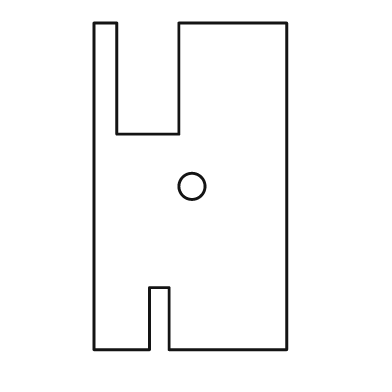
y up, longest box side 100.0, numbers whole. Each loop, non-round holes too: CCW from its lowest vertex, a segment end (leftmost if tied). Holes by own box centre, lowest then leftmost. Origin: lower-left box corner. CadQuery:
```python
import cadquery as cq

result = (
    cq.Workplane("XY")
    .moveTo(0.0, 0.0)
    .lineTo(17.0, 0.0)
    .lineTo(17.0, 19.0)
    .lineTo(23.0, 19.0)
    .lineTo(23.0, 0.0)
    .lineTo(59.0, 0.0)
    .lineTo(59.0, 100.0)
    .lineTo(26.0, 100.0)
    .lineTo(26.0, 66.0)
    .lineTo(7.0, 66.0)
    .lineTo(7.0, 100.0)
    .lineTo(0.0, 100.0)
    .close()
    .moveTo(30.0, 50.0)
    .circle(4.0)
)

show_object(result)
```